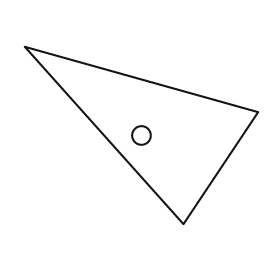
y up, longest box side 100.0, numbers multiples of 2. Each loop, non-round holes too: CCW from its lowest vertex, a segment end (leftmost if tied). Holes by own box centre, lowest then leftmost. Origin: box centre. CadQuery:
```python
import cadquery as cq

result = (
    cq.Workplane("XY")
    .moveTo(18.0, -38.0)
    .lineTo(50.0, 10.0)
    .lineTo(-50.0, 38.0)
    .close()
    .moveTo(0.0, 0.0)
    .circle(4.0)
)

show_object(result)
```